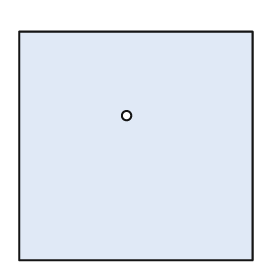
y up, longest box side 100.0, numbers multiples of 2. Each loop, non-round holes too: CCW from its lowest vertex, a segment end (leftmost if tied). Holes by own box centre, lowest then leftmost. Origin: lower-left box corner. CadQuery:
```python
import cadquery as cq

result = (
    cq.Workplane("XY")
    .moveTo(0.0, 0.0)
    .lineTo(100.0, 0.0)
    .lineTo(100.0, 98.0)
    .lineTo(0.0, 98.0)
    .close()
    .moveTo(46.0, 62.0)
    .circle(2.0)
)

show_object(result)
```